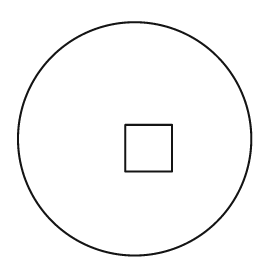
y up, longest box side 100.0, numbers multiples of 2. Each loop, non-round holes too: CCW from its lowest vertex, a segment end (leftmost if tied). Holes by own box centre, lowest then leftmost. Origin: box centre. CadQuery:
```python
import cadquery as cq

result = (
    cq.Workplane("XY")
    .moveTo(0.0, 0.0)
    .circle(50.0)
    .moveTo(-4.0, -14.0)
    .lineTo(16.0, -14.0)
    .lineTo(16.0, 6.0)
    .lineTo(-4.0, 6.0)
    .close()
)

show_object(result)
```